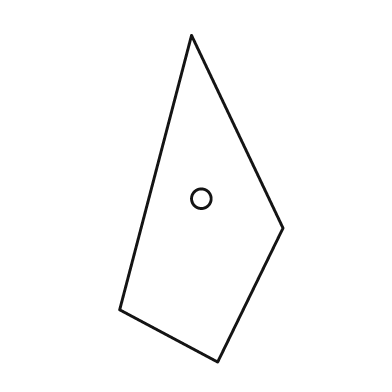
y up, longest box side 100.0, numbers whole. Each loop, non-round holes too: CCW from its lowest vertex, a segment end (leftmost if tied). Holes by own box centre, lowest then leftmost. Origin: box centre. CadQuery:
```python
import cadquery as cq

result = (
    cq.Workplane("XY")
    .moveTo(5.0, -50.0)
    .lineTo(25.0, -9.0)
    .lineTo(-3.0, 50.0)
    .lineTo(-25.0, -34.0)
    .close()
    .moveTo(0.0, 0.0)
    .circle(3.0)
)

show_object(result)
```